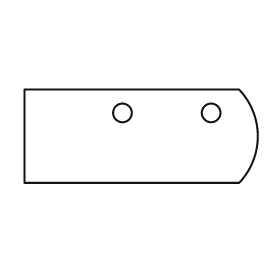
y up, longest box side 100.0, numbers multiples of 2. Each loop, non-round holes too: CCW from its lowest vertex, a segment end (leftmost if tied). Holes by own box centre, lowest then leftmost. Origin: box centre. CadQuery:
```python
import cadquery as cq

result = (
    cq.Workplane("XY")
    .moveTo(-50.0, -20.0)
    .lineTo(42.0, -20.0)
    .threePointArc((50.0, 0.0), (42.0, 20.0))
    .lineTo(-50.0, 20.0)
    .close()
    .moveTo(-8.0, 10.0)
    .circle(4.0)
    .moveTo(30.0, 10.0)
    .circle(4.0)
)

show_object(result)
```